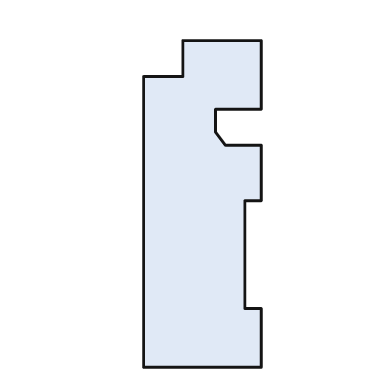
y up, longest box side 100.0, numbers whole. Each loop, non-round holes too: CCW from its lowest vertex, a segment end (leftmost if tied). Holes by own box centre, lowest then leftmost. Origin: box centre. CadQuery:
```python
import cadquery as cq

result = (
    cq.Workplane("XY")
    .moveTo(-18.0, -50.0)
    .lineTo(18.0, -50.0)
    .lineTo(18.0, -32.0)
    .lineTo(13.0, -32.0)
    .lineTo(13.0, 1.0)
    .lineTo(18.0, 1.0)
    .lineTo(18.0, 18.0)
    .lineTo(7.0, 18.0)
    .lineTo(4.0, 22.0)
    .lineTo(4.0, 29.0)
    .lineTo(18.0, 29.0)
    .lineTo(18.0, 50.0)
    .lineTo(-6.0, 50.0)
    .lineTo(-6.0, 39.0)
    .lineTo(-18.0, 39.0)
    .close()
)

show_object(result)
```